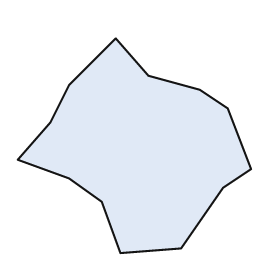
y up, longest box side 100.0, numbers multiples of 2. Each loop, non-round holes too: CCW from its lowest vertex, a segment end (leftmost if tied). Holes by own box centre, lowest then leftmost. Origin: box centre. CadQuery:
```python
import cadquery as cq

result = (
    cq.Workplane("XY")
    .moveTo(-6.0, -46.0)
    .lineTo(20.0, -44.0)
    .lineTo(38.0, -18.0)
    .lineTo(50.0, -10.0)
    .lineTo(40.0, 16.0)
    .lineTo(28.0, 24.0)
    .lineTo(6.0, 30.0)
    .lineTo(-8.0, 46.0)
    .lineTo(-28.0, 26.0)
    .lineTo(-36.0, 10.0)
    .lineTo(-50.0, -6.0)
    .lineTo(-28.0, -14.0)
    .lineTo(-14.0, -24.0)
    .close()
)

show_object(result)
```